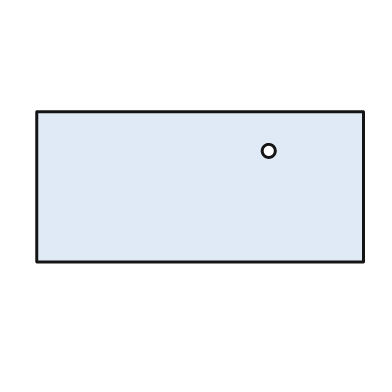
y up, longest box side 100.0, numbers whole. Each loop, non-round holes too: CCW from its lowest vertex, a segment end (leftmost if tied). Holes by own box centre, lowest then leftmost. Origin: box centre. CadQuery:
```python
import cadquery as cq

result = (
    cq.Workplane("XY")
    .moveTo(-50.0, -23.0)
    .lineTo(50.0, -23.0)
    .lineTo(50.0, 23.0)
    .lineTo(-50.0, 23.0)
    .close()
    .moveTo(21.0, 11.0)
    .circle(2.0)
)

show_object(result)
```